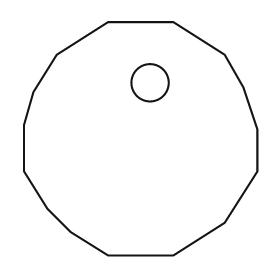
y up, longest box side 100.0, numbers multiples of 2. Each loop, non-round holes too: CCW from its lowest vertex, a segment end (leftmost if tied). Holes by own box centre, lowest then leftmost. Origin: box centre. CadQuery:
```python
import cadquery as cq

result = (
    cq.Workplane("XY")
    .moveTo(-14.0, -50.0)
    .lineTo(14.0, -50.0)
    .lineTo(36.0, -36.0)
    .lineTo(50.0, -14.0)
    .lineTo(50.0, 4.0)
    .lineTo(44.0, 22.0)
    .lineTo(36.0, 36.0)
    .lineTo(14.0, 50.0)
    .lineTo(-14.0, 50.0)
    .lineTo(-36.0, 36.0)
    .lineTo(-46.0, 20.0)
    .lineTo(-50.0, 6.0)
    .lineTo(-50.0, -14.0)
    .lineTo(-40.0, -30.0)
    .lineTo(-30.0, -40.0)
    .close()
    .moveTo(4.0, 24.0)
    .circle(8.0)
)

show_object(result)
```